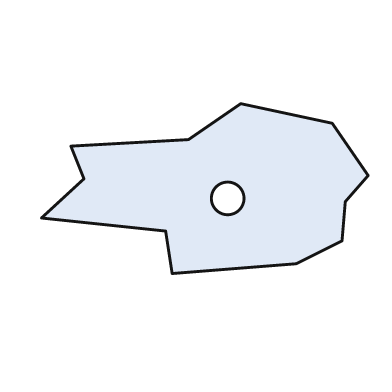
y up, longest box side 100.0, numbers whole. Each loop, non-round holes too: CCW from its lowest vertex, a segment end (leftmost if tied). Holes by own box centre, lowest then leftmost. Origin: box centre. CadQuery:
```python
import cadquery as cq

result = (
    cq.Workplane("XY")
    .moveTo(-10.0, -26.0)
    .lineTo(28.0, -23.0)
    .lineTo(42.0, -16.0)
    .lineTo(43.0, -4.0)
    .lineTo(50.0, 4.0)
    .lineTo(39.0, 20.0)
    .lineTo(11.0, 26.0)
    .lineTo(-5.0, 15.0)
    .lineTo(-41.0, 13.0)
    .lineTo(-37.0, 3.0)
    .lineTo(-50.0, -9.0)
    .lineTo(-12.0, -13.0)
    .close()
    .moveTo(7.0, -3.0)
    .circle(5.0)
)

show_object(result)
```